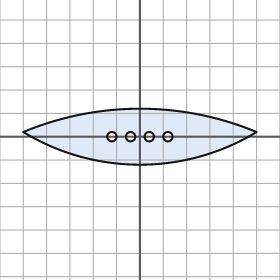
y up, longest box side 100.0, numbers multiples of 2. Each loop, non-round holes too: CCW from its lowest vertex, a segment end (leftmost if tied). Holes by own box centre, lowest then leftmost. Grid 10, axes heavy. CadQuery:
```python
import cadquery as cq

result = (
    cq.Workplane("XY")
    .moveTo(-50.0, 2.0)
    .threePointArc((0.0, -12.0), (50.0, 2.0))
    .threePointArc((0.0, 12.0), (-50.0, 2.0))
    .close()
    .moveTo(-12.0, 0.0)
    .circle(2.0)
    .moveTo(-4.0, 0.0)
    .circle(2.0)
    .moveTo(4.0, 0.0)
    .circle(2.0)
    .moveTo(12.0, 0.0)
    .circle(2.0)
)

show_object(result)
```